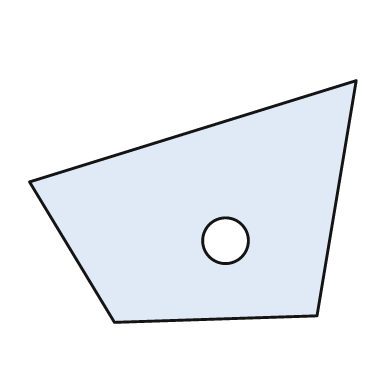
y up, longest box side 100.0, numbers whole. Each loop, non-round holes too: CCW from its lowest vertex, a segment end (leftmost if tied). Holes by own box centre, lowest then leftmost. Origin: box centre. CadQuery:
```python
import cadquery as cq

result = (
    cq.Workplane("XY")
    .moveTo(-24.0, -37.0)
    .lineTo(38.0, -35.0)
    .lineTo(50.0, 37.0)
    .lineTo(-50.0, 6.0)
    .close()
    .moveTo(10.0, -12.0)
    .circle(7.0)
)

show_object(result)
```